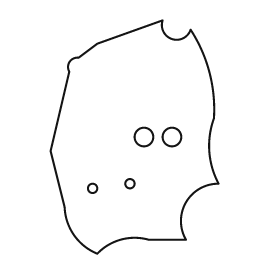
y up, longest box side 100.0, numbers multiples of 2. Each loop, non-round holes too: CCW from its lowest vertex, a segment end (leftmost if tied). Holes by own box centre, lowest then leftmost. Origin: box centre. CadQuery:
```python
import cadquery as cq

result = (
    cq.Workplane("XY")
    .moveTo(-16.0, -50.0)
    .threePointArc((-6.0, -44.0), (6.0, -44.0))
    .lineTo(22.0, -44.0)
    .threePointArc((22.0, -28.0), (36.0, -20.0))
    .threePointArc((32.0, -6.0), (34.0, 8.0))
    .threePointArc((32.0, 28.0), (24.0, 46.0))
    .threePointArc((16.0, 42.0), (12.0, 50.0))
    .lineTo(-16.0, 40.0)
    .lineTo(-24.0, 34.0)
    .threePointArc((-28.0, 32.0), (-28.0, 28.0))
    .lineTo(-36.0, -6.0)
    .lineTo(-30.0, -30.0)
    .threePointArc((-26.0, -42.0), (-16.0, -50.0))
    .close()
    .moveTo(-18.0, -22.0)
    .circle(2.0)
    .moveTo(-2.0, -20.0)
    .circle(2.0)
    .moveTo(4.0, 0.0)
    .circle(4.0)
    .moveTo(16.0, 0.0)
    .circle(4.0)
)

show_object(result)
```